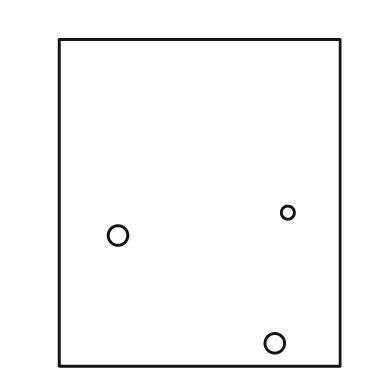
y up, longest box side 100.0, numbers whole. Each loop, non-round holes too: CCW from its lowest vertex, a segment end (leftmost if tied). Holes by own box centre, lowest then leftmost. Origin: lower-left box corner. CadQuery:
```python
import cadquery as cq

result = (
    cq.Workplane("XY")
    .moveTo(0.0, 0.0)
    .lineTo(86.0, 0.0)
    .lineTo(86.0, 100.0)
    .lineTo(0.0, 100.0)
    .close()
    .moveTo(66.0, 7.0)
    .circle(3.0)
    .moveTo(18.0, 40.0)
    .circle(3.0)
    .moveTo(70.0, 47.0)
    .circle(2.0)
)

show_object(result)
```